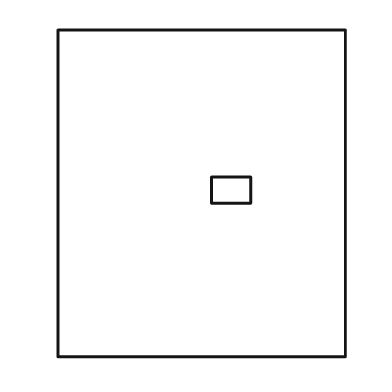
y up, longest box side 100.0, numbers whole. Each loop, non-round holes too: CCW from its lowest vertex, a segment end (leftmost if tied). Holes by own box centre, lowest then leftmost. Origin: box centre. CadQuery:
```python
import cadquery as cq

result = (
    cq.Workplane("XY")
    .moveTo(-44.0, -50.0)
    .lineTo(44.0, -50.0)
    .lineTo(44.0, 50.0)
    .lineTo(-44.0, 50.0)
    .close()
    .moveTo(3.0, -3.0)
    .lineTo(15.0, -3.0)
    .lineTo(15.0, 5.0)
    .lineTo(3.0, 5.0)
    .close()
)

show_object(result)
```